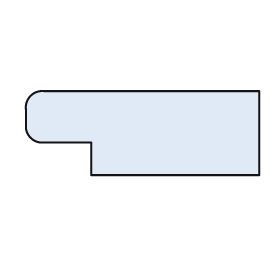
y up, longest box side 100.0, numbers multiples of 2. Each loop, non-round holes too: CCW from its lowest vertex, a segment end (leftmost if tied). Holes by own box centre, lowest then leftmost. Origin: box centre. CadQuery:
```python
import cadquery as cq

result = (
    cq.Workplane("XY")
    .moveTo(-22.0, -18.0)
    .lineTo(50.0, -18.0)
    .lineTo(50.0, 18.0)
    .lineTo(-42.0, 18.0)
    .threePointArc((-48.0, 16.0), (-50.0, 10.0))
    .lineTo(-50.0, 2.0)
    .threePointArc((-48.0, -2.0), (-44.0, -4.0))
    .lineTo(-22.0, -4.0)
    .close()
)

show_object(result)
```